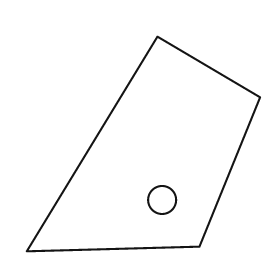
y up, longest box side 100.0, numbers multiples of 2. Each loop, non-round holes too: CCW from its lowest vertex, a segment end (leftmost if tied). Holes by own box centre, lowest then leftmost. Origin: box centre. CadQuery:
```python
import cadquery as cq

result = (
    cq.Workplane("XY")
    .moveTo(-50.0, -46.0)
    .lineTo(24.0, -44.0)
    .lineTo(50.0, 20.0)
    .lineTo(6.0, 46.0)
    .close()
    .moveTo(8.0, -24.0)
    .circle(6.0)
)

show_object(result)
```